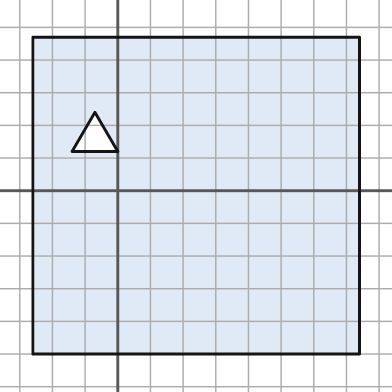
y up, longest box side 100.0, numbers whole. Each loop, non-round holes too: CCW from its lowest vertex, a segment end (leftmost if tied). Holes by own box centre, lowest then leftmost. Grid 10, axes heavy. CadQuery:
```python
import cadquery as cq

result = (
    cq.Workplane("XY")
    .moveTo(-26.0, -50.0)
    .lineTo(74.0, -50.0)
    .lineTo(74.0, 47.0)
    .lineTo(-26.0, 47.0)
    .close()
    .moveTo(-14.0, 12.0)
    .lineTo(0.0, 12.0)
    .lineTo(-7.0, 24.0)
    .close()
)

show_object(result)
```